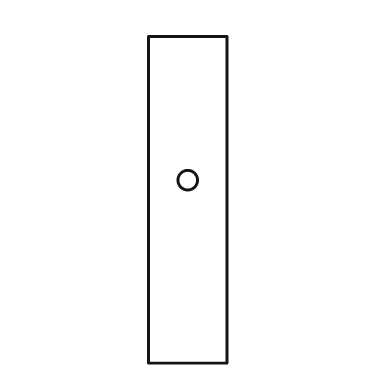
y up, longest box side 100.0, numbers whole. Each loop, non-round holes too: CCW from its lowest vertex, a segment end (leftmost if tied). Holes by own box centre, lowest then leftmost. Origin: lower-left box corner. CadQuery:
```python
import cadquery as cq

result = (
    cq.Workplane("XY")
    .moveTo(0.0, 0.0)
    .lineTo(24.0, 0.0)
    .lineTo(24.0, 100.0)
    .lineTo(0.0, 100.0)
    .close()
    .moveTo(12.0, 56.0)
    .circle(3.0)
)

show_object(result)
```